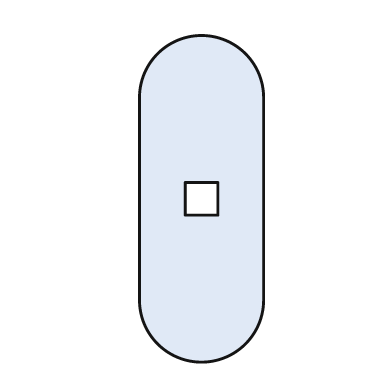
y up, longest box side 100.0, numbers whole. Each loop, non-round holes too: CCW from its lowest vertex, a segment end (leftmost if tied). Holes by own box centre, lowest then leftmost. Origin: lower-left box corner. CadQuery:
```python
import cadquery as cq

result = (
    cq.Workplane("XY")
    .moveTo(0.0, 19.0)
    .threePointArc((19.0, 0.0), (38.0, 19.0))
    .lineTo(38.0, 81.0)
    .threePointArc((19.0, 100.0), (0.0, 81.0))
    .close()
    .moveTo(14.0, 45.0)
    .lineTo(24.0, 45.0)
    .lineTo(24.0, 55.0)
    .lineTo(14.0, 55.0)
    .close()
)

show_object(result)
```